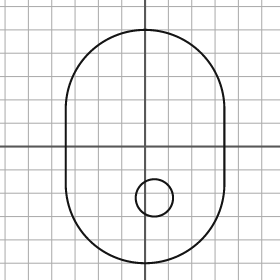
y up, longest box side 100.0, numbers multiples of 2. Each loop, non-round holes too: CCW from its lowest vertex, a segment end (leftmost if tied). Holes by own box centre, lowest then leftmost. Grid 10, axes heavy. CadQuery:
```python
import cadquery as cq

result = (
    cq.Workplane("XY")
    .moveTo(-34.0, -16.0)
    .threePointArc((0.0, -50.0), (34.0, -16.0))
    .lineTo(34.0, 16.0)
    .threePointArc((0.0, 50.0), (-34.0, 16.0))
    .close()
    .moveTo(4.0, -22.0)
    .circle(8.0)
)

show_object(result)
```